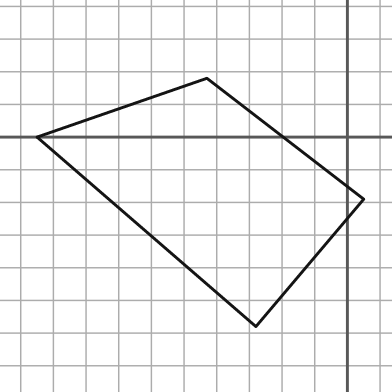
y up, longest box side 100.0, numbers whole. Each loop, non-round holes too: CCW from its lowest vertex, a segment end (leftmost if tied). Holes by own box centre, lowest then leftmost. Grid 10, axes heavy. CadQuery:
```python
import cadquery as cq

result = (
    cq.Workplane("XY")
    .moveTo(-28.0, -58.0)
    .lineTo(5.0, -19.0)
    .lineTo(-43.0, 18.0)
    .lineTo(-95.0, 0.0)
    .close()
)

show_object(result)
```